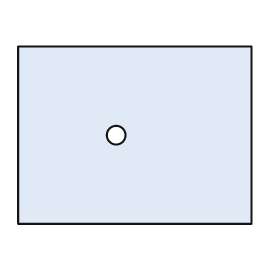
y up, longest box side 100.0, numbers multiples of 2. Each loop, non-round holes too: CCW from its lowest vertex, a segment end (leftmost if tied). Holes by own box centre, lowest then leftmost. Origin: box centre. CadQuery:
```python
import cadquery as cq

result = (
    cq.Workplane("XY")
    .moveTo(-50.0, -38.0)
    .lineTo(50.0, -38.0)
    .lineTo(50.0, 38.0)
    .lineTo(-50.0, 38.0)
    .close()
    .moveTo(-8.0, 0.0)
    .circle(4.0)
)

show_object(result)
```